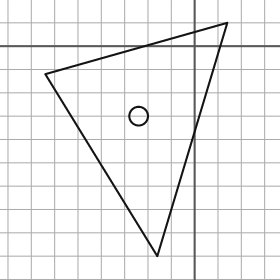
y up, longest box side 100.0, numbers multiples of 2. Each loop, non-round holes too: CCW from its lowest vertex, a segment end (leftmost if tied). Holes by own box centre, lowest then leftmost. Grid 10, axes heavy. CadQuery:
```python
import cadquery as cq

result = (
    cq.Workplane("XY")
    .moveTo(-16.0, -90.0)
    .lineTo(14.0, 10.0)
    .lineTo(-64.0, -12.0)
    .close()
    .moveTo(-24.0, -30.0)
    .circle(4.0)
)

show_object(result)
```